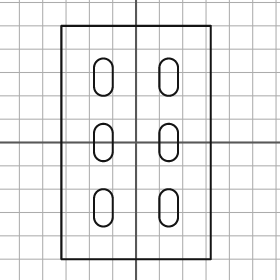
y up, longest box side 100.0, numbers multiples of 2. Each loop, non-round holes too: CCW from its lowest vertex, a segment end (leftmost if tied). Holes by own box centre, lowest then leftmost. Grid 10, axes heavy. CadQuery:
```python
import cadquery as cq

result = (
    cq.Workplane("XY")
    .moveTo(-32.0, -50.0)
    .lineTo(32.0, -50.0)
    .lineTo(32.0, 50.0)
    .lineTo(-32.0, 50.0)
    .close()
    .moveTo(-18.0, -32.0)
    .threePointArc((-14.0, -36.0), (-10.0, -32.0))
    .lineTo(-10.0, -24.0)
    .threePointArc((-14.0, -20.0), (-18.0, -24.0))
    .close()
    .moveTo(10.0, -32.0)
    .threePointArc((14.0, -36.0), (18.0, -32.0))
    .lineTo(18.0, -24.0)
    .threePointArc((14.0, -20.0), (10.0, -24.0))
    .close()
    .moveTo(-18.0, -4.0)
    .threePointArc((-14.0, -8.0), (-10.0, -4.0))
    .lineTo(-10.0, 4.0)
    .threePointArc((-14.0, 8.0), (-18.0, 4.0))
    .close()
    .moveTo(10.0, -4.0)
    .threePointArc((14.0, -8.0), (18.0, -4.0))
    .lineTo(18.0, 4.0)
    .threePointArc((14.0, 8.0), (10.0, 4.0))
    .close()
    .moveTo(-18.0, 24.0)
    .threePointArc((-14.0, 20.0), (-10.0, 24.0))
    .lineTo(-10.0, 32.0)
    .threePointArc((-14.0, 36.0), (-18.0, 32.0))
    .close()
    .moveTo(10.0, 24.0)
    .threePointArc((14.0, 20.0), (18.0, 24.0))
    .lineTo(18.0, 32.0)
    .threePointArc((14.0, 36.0), (10.0, 32.0))
    .close()
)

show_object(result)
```